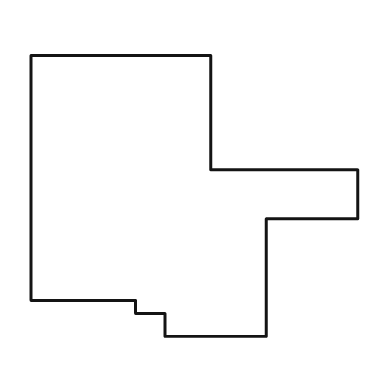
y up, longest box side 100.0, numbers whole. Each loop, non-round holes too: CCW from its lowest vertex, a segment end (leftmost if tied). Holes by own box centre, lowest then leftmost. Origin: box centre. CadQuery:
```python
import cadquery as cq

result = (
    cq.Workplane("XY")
    .moveTo(-9.0, -43.0)
    .lineTo(22.0, -43.0)
    .lineTo(22.0, -7.0)
    .lineTo(50.0, -7.0)
    .lineTo(50.0, 8.0)
    .lineTo(5.0, 8.0)
    .lineTo(5.0, 43.0)
    .lineTo(-50.0, 43.0)
    .lineTo(-50.0, -32.0)
    .lineTo(-18.0, -32.0)
    .lineTo(-18.0, -36.0)
    .lineTo(-9.0, -36.0)
    .close()
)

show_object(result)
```